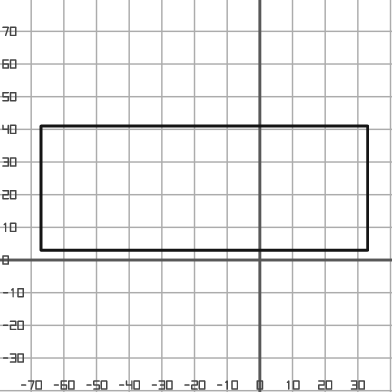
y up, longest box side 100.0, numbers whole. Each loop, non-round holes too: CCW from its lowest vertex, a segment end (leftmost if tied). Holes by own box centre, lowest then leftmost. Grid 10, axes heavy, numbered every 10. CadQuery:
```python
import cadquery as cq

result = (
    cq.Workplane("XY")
    .moveTo(-67.0, 3.0)
    .lineTo(33.0, 3.0)
    .lineTo(33.0, 41.0)
    .lineTo(-67.0, 41.0)
    .close()
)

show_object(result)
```